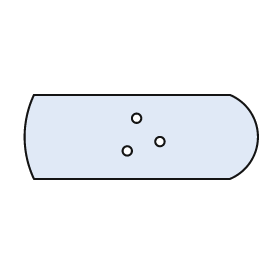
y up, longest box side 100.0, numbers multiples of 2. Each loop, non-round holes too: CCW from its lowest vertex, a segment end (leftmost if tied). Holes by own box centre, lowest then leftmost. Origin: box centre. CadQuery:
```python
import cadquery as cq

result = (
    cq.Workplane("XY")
    .moveTo(-46.0, -18.0)
    .lineTo(38.0, -18.0)
    .threePointArc((50.0, 0.0), (38.0, 18.0))
    .lineTo(-46.0, 18.0)
    .threePointArc((-50.0, 0.0), (-46.0, -18.0))
    .close()
    .moveTo(-6.0, -6.0)
    .circle(2.0)
    .moveTo(8.0, -2.0)
    .circle(2.0)
    .moveTo(-2.0, 8.0)
    .circle(2.0)
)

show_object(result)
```